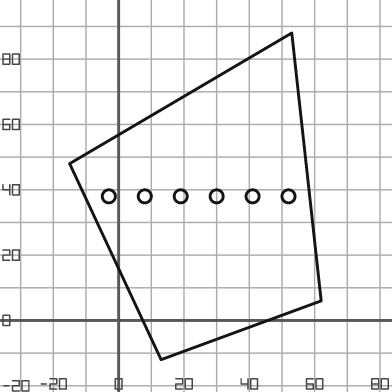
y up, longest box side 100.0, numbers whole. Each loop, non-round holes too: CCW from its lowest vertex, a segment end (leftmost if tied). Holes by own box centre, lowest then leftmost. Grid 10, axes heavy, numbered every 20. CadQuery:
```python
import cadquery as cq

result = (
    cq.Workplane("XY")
    .moveTo(13.0, -12.0)
    .lineTo(62.0, 6.0)
    .lineTo(53.0, 88.0)
    .lineTo(-15.0, 48.0)
    .close()
    .moveTo(-3.0, 38.0)
    .circle(2.0)
    .moveTo(8.0, 38.0)
    .circle(2.0)
    .moveTo(19.0, 38.0)
    .circle(2.0)
    .moveTo(30.0, 38.0)
    .circle(2.0)
    .moveTo(41.0, 38.0)
    .circle(2.0)
    .moveTo(52.0, 38.0)
    .circle(2.0)
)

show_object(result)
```